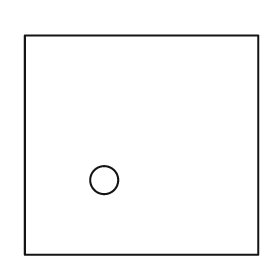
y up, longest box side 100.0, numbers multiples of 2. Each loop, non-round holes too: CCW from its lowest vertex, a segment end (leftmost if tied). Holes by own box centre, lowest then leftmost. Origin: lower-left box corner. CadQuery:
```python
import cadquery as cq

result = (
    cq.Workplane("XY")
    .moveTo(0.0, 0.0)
    .lineTo(100.0, 0.0)
    .lineTo(100.0, 94.0)
    .lineTo(0.0, 94.0)
    .close()
    .moveTo(34.0, 32.0)
    .circle(6.0)
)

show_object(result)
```